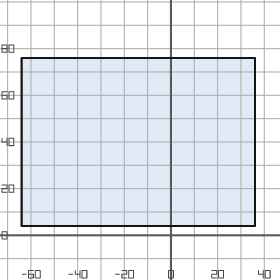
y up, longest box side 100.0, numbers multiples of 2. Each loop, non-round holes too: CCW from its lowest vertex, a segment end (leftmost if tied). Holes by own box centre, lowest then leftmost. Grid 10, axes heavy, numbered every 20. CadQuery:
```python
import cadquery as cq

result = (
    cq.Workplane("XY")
    .moveTo(-64.0, 4.0)
    .lineTo(36.0, 4.0)
    .lineTo(36.0, 76.0)
    .lineTo(-64.0, 76.0)
    .close()
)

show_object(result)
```